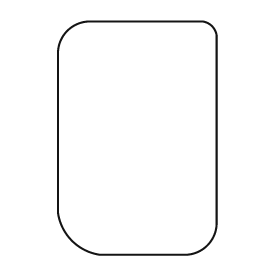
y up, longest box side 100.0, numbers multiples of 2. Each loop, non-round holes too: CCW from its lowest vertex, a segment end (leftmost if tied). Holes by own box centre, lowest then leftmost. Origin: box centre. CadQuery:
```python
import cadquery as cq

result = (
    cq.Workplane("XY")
    .moveTo(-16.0, -50.0)
    .lineTo(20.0, -50.0)
    .threePointArc((30.0, -46.0), (34.0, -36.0))
    .lineTo(34.0, 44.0)
    .threePointArc((32.0, 48.0), (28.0, 50.0))
    .lineTo(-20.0, 50.0)
    .threePointArc((-30.0, 46.0), (-34.0, 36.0))
    .lineTo(-34.0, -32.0)
    .threePointArc((-28.0, -44.0), (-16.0, -50.0))
    .close()
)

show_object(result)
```